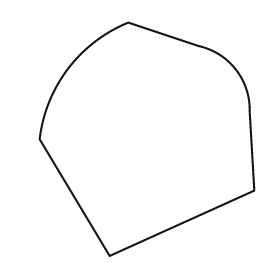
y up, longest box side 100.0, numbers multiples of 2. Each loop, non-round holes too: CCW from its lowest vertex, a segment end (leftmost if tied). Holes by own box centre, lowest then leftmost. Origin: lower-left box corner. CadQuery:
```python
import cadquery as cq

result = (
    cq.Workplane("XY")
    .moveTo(30.0, 0.0)
    .lineTo(92.0, 28.0)
    .lineTo(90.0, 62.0)
    .threePointArc((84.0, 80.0), (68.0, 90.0))
    .lineTo(38.0, 100.0)
    .threePointArc((12.0, 80.0), (0.0, 50.0))
    .close()
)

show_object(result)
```